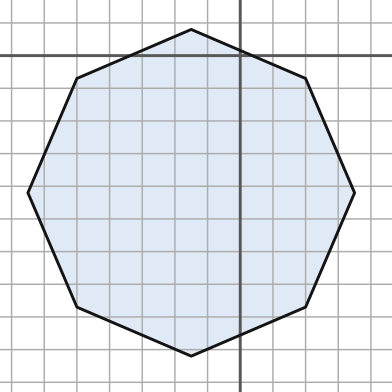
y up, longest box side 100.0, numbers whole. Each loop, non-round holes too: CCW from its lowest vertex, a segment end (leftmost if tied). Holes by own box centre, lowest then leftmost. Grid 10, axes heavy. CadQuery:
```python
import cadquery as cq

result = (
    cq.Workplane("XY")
    .moveTo(-15.0, -92.0)
    .lineTo(20.0, -77.0)
    .lineTo(35.0, -42.0)
    .lineTo(20.0, -7.0)
    .lineTo(-15.0, 8.0)
    .lineTo(-50.0, -7.0)
    .lineTo(-65.0, -42.0)
    .lineTo(-50.0, -77.0)
    .close()
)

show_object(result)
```